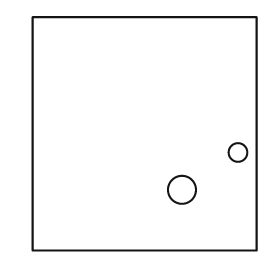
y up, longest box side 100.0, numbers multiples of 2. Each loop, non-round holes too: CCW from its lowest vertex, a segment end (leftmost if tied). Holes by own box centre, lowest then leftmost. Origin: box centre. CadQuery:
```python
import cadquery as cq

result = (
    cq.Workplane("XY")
    .moveTo(-48.0, -50.0)
    .lineTo(48.0, -50.0)
    .lineTo(48.0, 50.0)
    .lineTo(-48.0, 50.0)
    .close()
    .moveTo(16.0, -24.0)
    .circle(6.0)
    .moveTo(40.0, -8.0)
    .circle(4.0)
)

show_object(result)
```